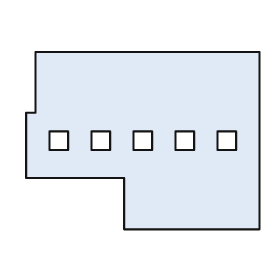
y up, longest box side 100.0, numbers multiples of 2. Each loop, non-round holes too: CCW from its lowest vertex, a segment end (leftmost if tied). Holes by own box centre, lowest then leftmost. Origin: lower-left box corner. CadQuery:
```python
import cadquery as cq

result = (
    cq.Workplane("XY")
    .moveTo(42.0, 0.0)
    .lineTo(100.0, 0.0)
    .lineTo(100.0, 76.0)
    .lineTo(4.0, 76.0)
    .lineTo(4.0, 50.0)
    .lineTo(0.0, 50.0)
    .lineTo(0.0, 22.0)
    .lineTo(42.0, 22.0)
    .close()
    .moveTo(10.0, 34.0)
    .lineTo(18.0, 34.0)
    .lineTo(18.0, 42.0)
    .lineTo(10.0, 42.0)
    .close()
    .moveTo(28.0, 34.0)
    .lineTo(36.0, 34.0)
    .lineTo(36.0, 42.0)
    .lineTo(28.0, 42.0)
    .close()
    .moveTo(46.0, 34.0)
    .lineTo(54.0, 34.0)
    .lineTo(54.0, 42.0)
    .lineTo(46.0, 42.0)
    .close()
    .moveTo(64.0, 34.0)
    .lineTo(72.0, 34.0)
    .lineTo(72.0, 42.0)
    .lineTo(64.0, 42.0)
    .close()
    .moveTo(82.0, 34.0)
    .lineTo(90.0, 34.0)
    .lineTo(90.0, 42.0)
    .lineTo(82.0, 42.0)
    .close()
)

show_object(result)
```